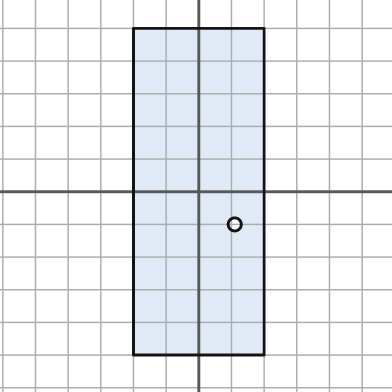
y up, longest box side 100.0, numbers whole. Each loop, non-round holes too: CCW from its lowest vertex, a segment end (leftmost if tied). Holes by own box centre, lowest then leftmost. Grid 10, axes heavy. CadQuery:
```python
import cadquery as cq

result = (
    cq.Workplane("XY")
    .moveTo(-20.0, -50.0)
    .lineTo(20.0, -50.0)
    .lineTo(20.0, 50.0)
    .lineTo(-20.0, 50.0)
    .close()
    .moveTo(11.0, -10.0)
    .circle(2.0)
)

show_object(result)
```